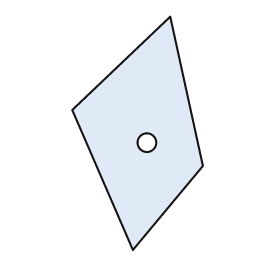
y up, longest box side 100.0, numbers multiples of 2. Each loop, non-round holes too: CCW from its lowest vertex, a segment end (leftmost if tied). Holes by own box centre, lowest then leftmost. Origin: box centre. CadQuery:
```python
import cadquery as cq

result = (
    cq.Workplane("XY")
    .moveTo(-2.0, -50.0)
    .lineTo(28.0, -14.0)
    .lineTo(14.0, 50.0)
    .lineTo(-28.0, 10.0)
    .close()
    .moveTo(4.0, -4.0)
    .circle(4.0)
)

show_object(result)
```